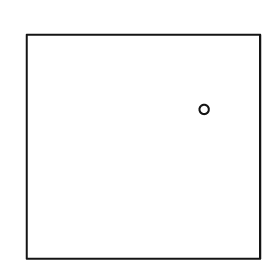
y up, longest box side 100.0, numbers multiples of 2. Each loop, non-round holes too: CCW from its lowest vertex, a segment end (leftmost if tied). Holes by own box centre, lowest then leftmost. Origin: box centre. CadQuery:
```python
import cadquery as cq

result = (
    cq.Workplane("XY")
    .moveTo(-50.0, -48.0)
    .lineTo(50.0, -48.0)
    .lineTo(50.0, 48.0)
    .lineTo(-50.0, 48.0)
    .close()
    .moveTo(26.0, 16.0)
    .circle(2.0)
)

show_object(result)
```